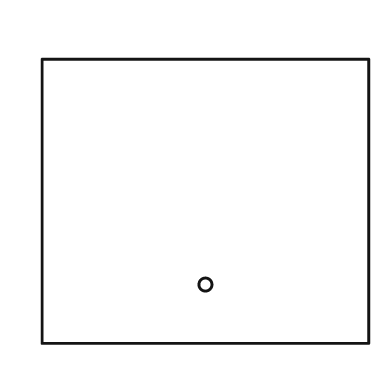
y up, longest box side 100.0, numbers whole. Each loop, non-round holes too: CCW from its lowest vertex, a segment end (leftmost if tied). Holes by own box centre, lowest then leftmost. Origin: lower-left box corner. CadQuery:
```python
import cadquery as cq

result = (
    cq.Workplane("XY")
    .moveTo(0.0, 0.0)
    .lineTo(100.0, 0.0)
    .lineTo(100.0, 87.0)
    .lineTo(0.0, 87.0)
    .close()
    .moveTo(50.0, 18.0)
    .circle(2.0)
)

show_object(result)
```